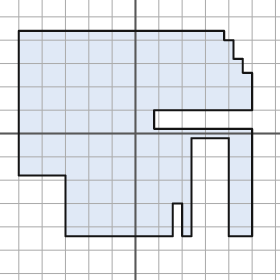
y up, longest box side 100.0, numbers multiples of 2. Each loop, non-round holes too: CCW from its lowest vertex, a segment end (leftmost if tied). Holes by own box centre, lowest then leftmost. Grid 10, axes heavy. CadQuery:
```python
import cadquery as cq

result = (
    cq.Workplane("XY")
    .moveTo(-30.0, -44.0)
    .lineTo(16.0, -44.0)
    .lineTo(16.0, -30.0)
    .lineTo(20.0, -30.0)
    .lineTo(20.0, -44.0)
    .lineTo(24.0, -44.0)
    .lineTo(24.0, -2.0)
    .lineTo(40.0, -2.0)
    .lineTo(40.0, -44.0)
    .lineTo(50.0, -44.0)
    .lineTo(50.0, 2.0)
    .lineTo(8.0, 2.0)
    .lineTo(8.0, 10.0)
    .lineTo(50.0, 10.0)
    .lineTo(50.0, 26.0)
    .lineTo(46.0, 26.0)
    .lineTo(46.0, 32.0)
    .lineTo(42.0, 32.0)
    .lineTo(42.0, 40.0)
    .lineTo(38.0, 40.0)
    .lineTo(38.0, 44.0)
    .lineTo(-50.0, 44.0)
    .lineTo(-50.0, -18.0)
    .lineTo(-30.0, -18.0)
    .close()
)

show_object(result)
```